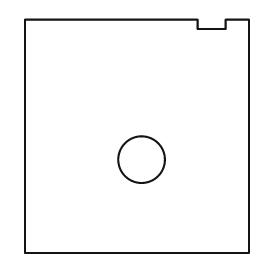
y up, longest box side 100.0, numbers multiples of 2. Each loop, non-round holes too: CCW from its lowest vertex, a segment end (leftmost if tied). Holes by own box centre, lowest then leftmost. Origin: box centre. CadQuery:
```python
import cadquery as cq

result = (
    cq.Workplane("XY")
    .moveTo(-48.0, -50.0)
    .lineTo(48.0, -50.0)
    .lineTo(48.0, 50.0)
    .lineTo(38.0, 50.0)
    .lineTo(38.0, 46.0)
    .lineTo(26.0, 46.0)
    .lineTo(26.0, 50.0)
    .lineTo(-48.0, 50.0)
    .close()
    .moveTo(2.0, -10.0)
    .circle(10.0)
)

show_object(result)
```